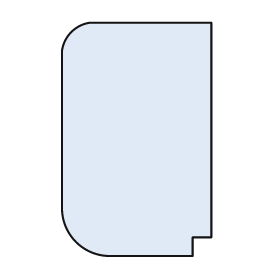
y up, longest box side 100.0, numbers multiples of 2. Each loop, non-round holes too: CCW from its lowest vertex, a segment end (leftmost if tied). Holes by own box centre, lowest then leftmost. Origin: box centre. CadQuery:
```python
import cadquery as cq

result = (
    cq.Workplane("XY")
    .moveTo(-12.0, -50.0)
    .lineTo(24.0, -50.0)
    .lineTo(24.0, -42.0)
    .lineTo(32.0, -42.0)
    .lineTo(32.0, 50.0)
    .lineTo(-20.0, 50.0)
    .threePointArc((-28.0, 46.0), (-32.0, 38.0))
    .lineTo(-32.0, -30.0)
    .threePointArc((-26.0, -44.0), (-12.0, -50.0))
    .close()
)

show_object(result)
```